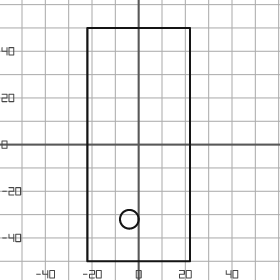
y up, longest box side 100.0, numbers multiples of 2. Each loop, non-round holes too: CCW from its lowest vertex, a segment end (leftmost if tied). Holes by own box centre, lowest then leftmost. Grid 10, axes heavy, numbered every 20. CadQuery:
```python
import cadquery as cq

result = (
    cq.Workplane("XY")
    .moveTo(-22.0, -50.0)
    .lineTo(22.0, -50.0)
    .lineTo(22.0, 50.0)
    .lineTo(-22.0, 50.0)
    .close()
    .moveTo(-4.0, -32.0)
    .circle(4.0)
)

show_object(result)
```